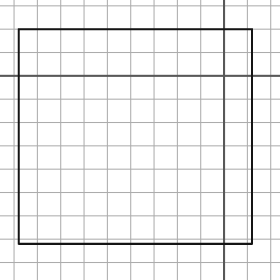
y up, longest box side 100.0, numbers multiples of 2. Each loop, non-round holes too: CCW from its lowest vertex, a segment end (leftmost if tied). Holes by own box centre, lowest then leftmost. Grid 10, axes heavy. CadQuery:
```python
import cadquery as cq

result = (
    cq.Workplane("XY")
    .moveTo(-88.0, -72.0)
    .lineTo(12.0, -72.0)
    .lineTo(12.0, 20.0)
    .lineTo(-88.0, 20.0)
    .close()
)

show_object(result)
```